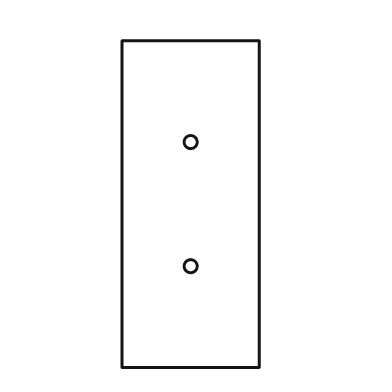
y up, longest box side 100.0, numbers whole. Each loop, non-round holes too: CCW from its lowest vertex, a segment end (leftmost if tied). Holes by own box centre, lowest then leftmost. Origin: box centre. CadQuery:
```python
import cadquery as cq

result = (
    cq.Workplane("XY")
    .moveTo(-21.0, -50.0)
    .lineTo(21.0, -50.0)
    .lineTo(21.0, 50.0)
    .lineTo(-21.0, 50.0)
    .close()
    .moveTo(0.0, -19.0)
    .circle(2.0)
    .moveTo(0.0, 19.0)
    .circle(2.0)
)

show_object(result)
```